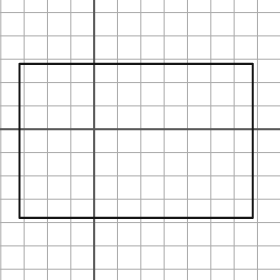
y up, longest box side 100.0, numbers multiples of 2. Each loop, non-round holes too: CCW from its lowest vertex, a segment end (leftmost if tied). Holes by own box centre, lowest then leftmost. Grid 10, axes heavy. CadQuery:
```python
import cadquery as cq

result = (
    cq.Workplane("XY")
    .moveTo(-32.0, -38.0)
    .lineTo(68.0, -38.0)
    .lineTo(68.0, 28.0)
    .lineTo(-32.0, 28.0)
    .close()
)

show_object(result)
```